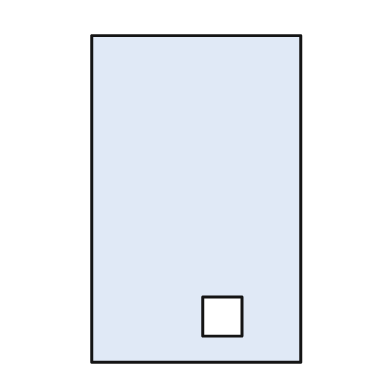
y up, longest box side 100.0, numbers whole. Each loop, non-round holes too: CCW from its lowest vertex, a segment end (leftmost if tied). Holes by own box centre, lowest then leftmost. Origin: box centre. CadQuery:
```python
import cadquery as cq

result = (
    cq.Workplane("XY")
    .moveTo(-32.0, -50.0)
    .lineTo(32.0, -50.0)
    .lineTo(32.0, 50.0)
    .lineTo(-32.0, 50.0)
    .close()
    .moveTo(2.0, -42.0)
    .lineTo(14.0, -42.0)
    .lineTo(14.0, -30.0)
    .lineTo(2.0, -30.0)
    .close()
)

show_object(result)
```